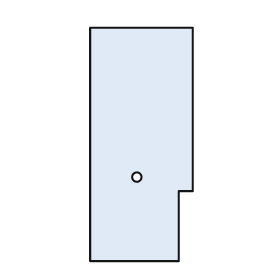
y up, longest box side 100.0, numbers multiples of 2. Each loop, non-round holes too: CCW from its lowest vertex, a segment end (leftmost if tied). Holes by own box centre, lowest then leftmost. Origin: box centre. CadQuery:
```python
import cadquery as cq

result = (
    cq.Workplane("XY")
    .moveTo(-22.0, -50.0)
    .lineTo(16.0, -50.0)
    .lineTo(16.0, -20.0)
    .lineTo(22.0, -20.0)
    .lineTo(22.0, 50.0)
    .lineTo(-22.0, 50.0)
    .close()
    .moveTo(-2.0, -14.0)
    .circle(2.0)
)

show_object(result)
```